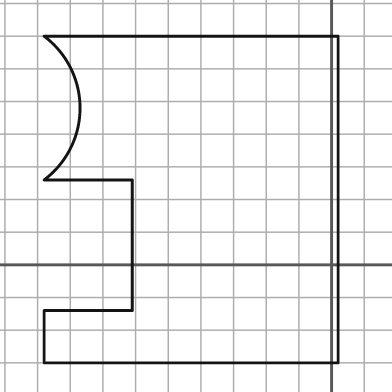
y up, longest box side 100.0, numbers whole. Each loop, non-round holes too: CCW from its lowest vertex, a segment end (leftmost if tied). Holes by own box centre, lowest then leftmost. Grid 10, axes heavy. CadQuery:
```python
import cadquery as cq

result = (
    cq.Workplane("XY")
    .moveTo(-88.0, -30.0)
    .lineTo(2.0, -30.0)
    .lineTo(2.0, 70.0)
    .lineTo(-88.0, 70.0)
    .threePointArc((-77.0, 48.0), (-88.0, 26.0))
    .lineTo(-61.0, 26.0)
    .lineTo(-61.0, -14.0)
    .lineTo(-88.0, -14.0)
    .close()
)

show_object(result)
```